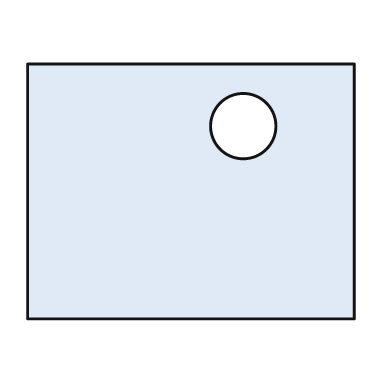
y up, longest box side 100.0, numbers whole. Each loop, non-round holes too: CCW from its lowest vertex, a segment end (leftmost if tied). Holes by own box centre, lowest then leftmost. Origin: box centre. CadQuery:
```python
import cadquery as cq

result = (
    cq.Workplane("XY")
    .moveTo(-50.0, -39.0)
    .lineTo(50.0, -39.0)
    .lineTo(50.0, 39.0)
    .lineTo(-50.0, 39.0)
    .close()
    .moveTo(16.0, 20.0)
    .circle(10.0)
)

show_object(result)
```